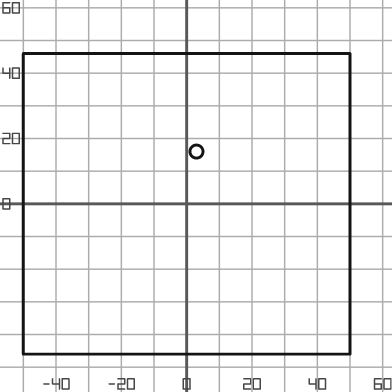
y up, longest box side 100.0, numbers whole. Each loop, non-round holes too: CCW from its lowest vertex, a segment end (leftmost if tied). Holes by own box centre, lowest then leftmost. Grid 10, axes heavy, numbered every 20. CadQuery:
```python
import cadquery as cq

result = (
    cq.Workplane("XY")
    .moveTo(-50.0, -46.0)
    .lineTo(50.0, -46.0)
    .lineTo(50.0, 46.0)
    .lineTo(-50.0, 46.0)
    .close()
    .moveTo(3.0, 16.0)
    .circle(2.0)
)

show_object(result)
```